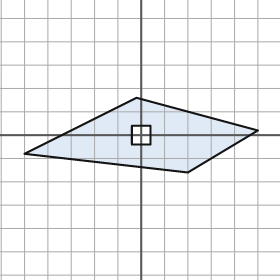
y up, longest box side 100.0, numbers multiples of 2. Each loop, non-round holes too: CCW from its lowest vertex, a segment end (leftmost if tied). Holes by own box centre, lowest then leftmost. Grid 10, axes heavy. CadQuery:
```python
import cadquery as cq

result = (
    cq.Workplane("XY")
    .moveTo(20.0, -16.0)
    .lineTo(50.0, 2.0)
    .lineTo(-2.0, 16.0)
    .lineTo(-50.0, -8.0)
    .close()
    .moveTo(-4.0, -4.0)
    .lineTo(4.0, -4.0)
    .lineTo(4.0, 4.0)
    .lineTo(-4.0, 4.0)
    .close()
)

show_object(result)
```